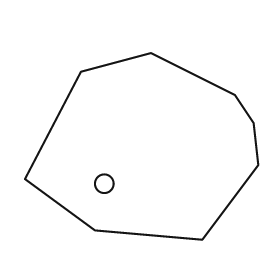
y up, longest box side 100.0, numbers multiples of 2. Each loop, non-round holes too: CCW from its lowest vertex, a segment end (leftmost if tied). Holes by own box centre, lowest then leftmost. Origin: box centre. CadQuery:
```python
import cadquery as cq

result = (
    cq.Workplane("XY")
    .moveTo(26.0, -40.0)
    .lineTo(50.0, -8.0)
    .lineTo(48.0, 10.0)
    .lineTo(40.0, 22.0)
    .lineTo(4.0, 40.0)
    .lineTo(-26.0, 32.0)
    .lineTo(-50.0, -14.0)
    .lineTo(-20.0, -36.0)
    .close()
    .moveTo(-16.0, -16.0)
    .circle(4.0)
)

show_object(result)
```